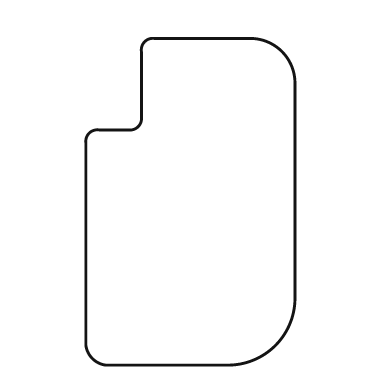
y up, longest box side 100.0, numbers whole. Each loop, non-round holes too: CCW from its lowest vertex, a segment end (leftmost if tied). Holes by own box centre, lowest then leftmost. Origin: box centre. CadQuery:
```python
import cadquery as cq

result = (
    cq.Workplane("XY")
    .moveTo(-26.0, -50.0)
    .lineTo(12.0, -50.0)
    .threePointArc((26.0, -44.0), (32.0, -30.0))
    .lineTo(32.0, 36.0)
    .threePointArc((28.0, 46.0), (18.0, 50.0))
    .lineTo(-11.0, 50.0)
    .threePointArc((-14.0, 49.0), (-15.0, 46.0))
    .lineTo(-15.0, 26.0)
    .threePointArc((-16.0, 23.0), (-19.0, 22.0))
    .lineTo(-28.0, 22.0)
    .threePointArc((-31.0, 21.0), (-32.0, 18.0))
    .lineTo(-32.0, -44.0)
    .threePointArc((-30.0, -48.0), (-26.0, -50.0))
    .close()
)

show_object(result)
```